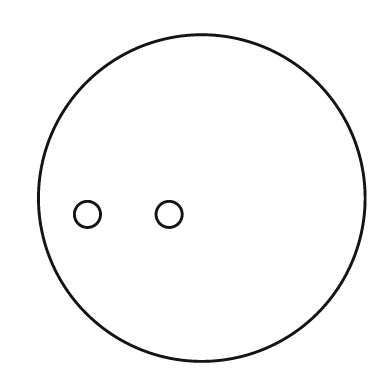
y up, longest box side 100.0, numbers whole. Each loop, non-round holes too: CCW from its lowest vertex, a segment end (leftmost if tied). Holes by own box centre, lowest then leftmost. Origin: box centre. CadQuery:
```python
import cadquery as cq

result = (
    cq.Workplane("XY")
    .moveTo(0.0, 0.0)
    .circle(50.0)
    .moveTo(-35.0, -5.0)
    .circle(4.0)
    .moveTo(-10.0, -5.0)
    .circle(4.0)
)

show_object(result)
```